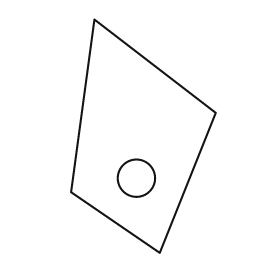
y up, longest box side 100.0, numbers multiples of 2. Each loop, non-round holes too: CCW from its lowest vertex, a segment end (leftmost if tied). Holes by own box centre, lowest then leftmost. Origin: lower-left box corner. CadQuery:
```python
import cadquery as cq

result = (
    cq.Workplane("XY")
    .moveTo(38.0, 0.0)
    .lineTo(62.0, 60.0)
    .lineTo(10.0, 100.0)
    .lineTo(0.0, 26.0)
    .close()
    .moveTo(28.0, 32.0)
    .circle(8.0)
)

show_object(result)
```